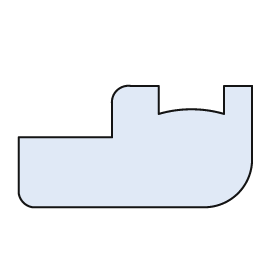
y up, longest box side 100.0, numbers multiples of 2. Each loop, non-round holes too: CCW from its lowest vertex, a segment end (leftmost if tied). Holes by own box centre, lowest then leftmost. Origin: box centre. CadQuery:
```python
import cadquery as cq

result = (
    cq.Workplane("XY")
    .moveTo(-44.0, -26.0)
    .lineTo(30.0, -26.0)
    .threePointArc((44.0, -20.0), (50.0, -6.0))
    .lineTo(50.0, 26.0)
    .lineTo(38.0, 26.0)
    .lineTo(38.0, 14.0)
    .threePointArc((24.0, 16.0), (10.0, 14.0))
    .lineTo(10.0, 26.0)
    .lineTo(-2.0, 26.0)
    .threePointArc((-8.0, 24.0), (-10.0, 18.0))
    .lineTo(-10.0, 4.0)
    .lineTo(-50.0, 4.0)
    .lineTo(-50.0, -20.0)
    .threePointArc((-48.0, -24.0), (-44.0, -26.0))
    .close()
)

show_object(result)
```